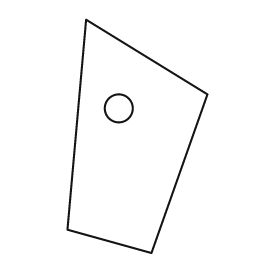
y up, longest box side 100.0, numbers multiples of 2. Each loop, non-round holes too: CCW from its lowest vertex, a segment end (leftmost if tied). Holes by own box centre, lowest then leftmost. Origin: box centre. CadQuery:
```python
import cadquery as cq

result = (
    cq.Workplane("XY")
    .moveTo(6.0, -50.0)
    .lineTo(30.0, 18.0)
    .lineTo(-22.0, 50.0)
    .lineTo(-30.0, -40.0)
    .close()
    .moveTo(-8.0, 12.0)
    .circle(6.0)
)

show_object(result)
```